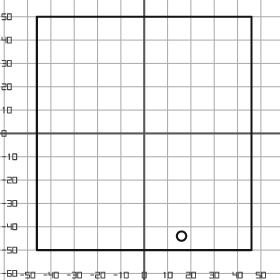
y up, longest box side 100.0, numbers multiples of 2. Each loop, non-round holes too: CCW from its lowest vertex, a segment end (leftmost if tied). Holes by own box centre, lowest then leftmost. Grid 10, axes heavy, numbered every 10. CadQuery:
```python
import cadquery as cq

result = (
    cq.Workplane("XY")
    .moveTo(-46.0, -50.0)
    .lineTo(46.0, -50.0)
    .lineTo(46.0, 50.0)
    .lineTo(-46.0, 50.0)
    .close()
    .moveTo(16.0, -44.0)
    .circle(2.0)
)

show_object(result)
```